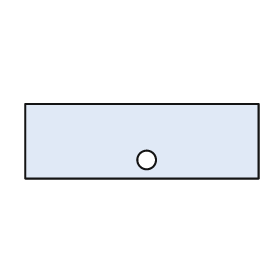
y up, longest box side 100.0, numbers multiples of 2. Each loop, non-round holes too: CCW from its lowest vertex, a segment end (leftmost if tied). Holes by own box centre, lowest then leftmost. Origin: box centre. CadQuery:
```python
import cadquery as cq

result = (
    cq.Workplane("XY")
    .moveTo(-50.0, -16.0)
    .lineTo(50.0, -16.0)
    .lineTo(50.0, 16.0)
    .lineTo(-50.0, 16.0)
    .close()
    .moveTo(2.0, -8.0)
    .circle(4.0)
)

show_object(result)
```